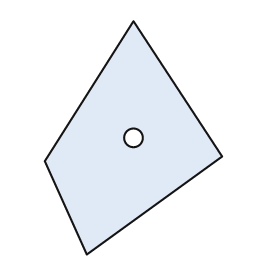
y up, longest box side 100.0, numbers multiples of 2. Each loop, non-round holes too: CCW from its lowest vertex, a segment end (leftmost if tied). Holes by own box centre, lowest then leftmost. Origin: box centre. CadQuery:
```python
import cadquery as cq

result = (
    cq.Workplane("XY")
    .moveTo(-20.0, -50.0)
    .lineTo(38.0, -8.0)
    .lineTo(0.0, 50.0)
    .lineTo(-38.0, -10.0)
    .close()
    .moveTo(0.0, 0.0)
    .circle(4.0)
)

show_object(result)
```